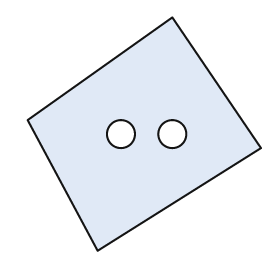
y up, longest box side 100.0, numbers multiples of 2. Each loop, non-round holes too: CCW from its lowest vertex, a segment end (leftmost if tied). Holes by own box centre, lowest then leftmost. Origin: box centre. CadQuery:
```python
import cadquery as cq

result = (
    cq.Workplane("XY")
    .moveTo(-20.0, -50.0)
    .lineTo(50.0, -6.0)
    .lineTo(12.0, 50.0)
    .lineTo(-50.0, 6.0)
    .close()
    .moveTo(-10.0, 0.0)
    .circle(6.0)
    .moveTo(12.0, 0.0)
    .circle(6.0)
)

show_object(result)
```